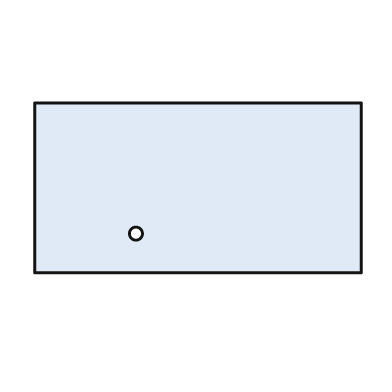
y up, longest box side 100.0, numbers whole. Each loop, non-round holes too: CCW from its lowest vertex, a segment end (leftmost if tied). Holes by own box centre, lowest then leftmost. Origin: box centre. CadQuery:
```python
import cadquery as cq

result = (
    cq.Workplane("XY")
    .moveTo(-50.0, -26.0)
    .lineTo(50.0, -26.0)
    .lineTo(50.0, 26.0)
    .lineTo(-50.0, 26.0)
    .close()
    .moveTo(-19.0, -14.0)
    .circle(2.0)
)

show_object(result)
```